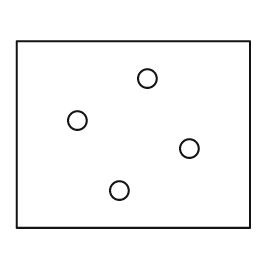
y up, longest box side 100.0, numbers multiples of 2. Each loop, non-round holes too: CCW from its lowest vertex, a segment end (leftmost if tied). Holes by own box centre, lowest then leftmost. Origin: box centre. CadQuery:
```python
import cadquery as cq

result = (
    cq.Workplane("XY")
    .moveTo(-50.0, -40.0)
    .lineTo(50.0, -40.0)
    .lineTo(50.0, 40.0)
    .lineTo(-50.0, 40.0)
    .close()
    .moveTo(-6.0, -24.0)
    .circle(4.0)
    .moveTo(24.0, -6.0)
    .circle(4.0)
    .moveTo(-24.0, 6.0)
    .circle(4.0)
    .moveTo(6.0, 24.0)
    .circle(4.0)
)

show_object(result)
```